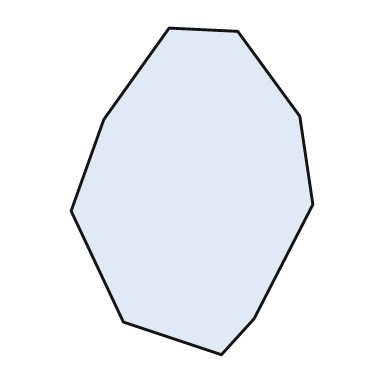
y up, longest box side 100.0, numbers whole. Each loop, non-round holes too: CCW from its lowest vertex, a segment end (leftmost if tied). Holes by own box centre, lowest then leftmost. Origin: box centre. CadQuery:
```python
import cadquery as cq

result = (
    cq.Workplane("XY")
    .moveTo(9.0, -50.0)
    .lineTo(19.0, -39.0)
    .lineTo(37.0, -4.0)
    .lineTo(33.0, 23.0)
    .lineTo(14.0, 49.0)
    .lineTo(-7.0, 50.0)
    .lineTo(-27.0, 22.0)
    .lineTo(-37.0, -6.0)
    .lineTo(-21.0, -40.0)
    .close()
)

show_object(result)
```